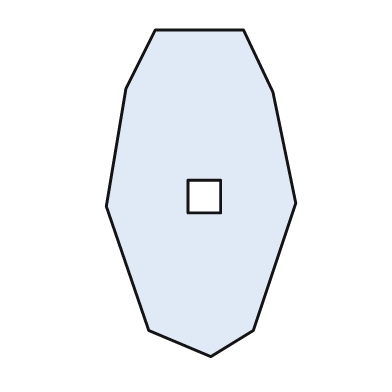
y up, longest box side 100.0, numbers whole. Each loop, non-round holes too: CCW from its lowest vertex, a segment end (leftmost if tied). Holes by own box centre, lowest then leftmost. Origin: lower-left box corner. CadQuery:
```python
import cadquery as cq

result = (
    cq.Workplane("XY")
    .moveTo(32.0, 0.0)
    .lineTo(45.0, 8.0)
    .lineTo(58.0, 47.0)
    .lineTo(51.0, 81.0)
    .lineTo(42.0, 100.0)
    .lineTo(15.0, 100.0)
    .lineTo(6.0, 82.0)
    .lineTo(0.0, 46.0)
    .lineTo(13.0, 8.0)
    .close()
    .moveTo(25.0, 44.0)
    .lineTo(35.0, 44.0)
    .lineTo(35.0, 54.0)
    .lineTo(25.0, 54.0)
    .close()
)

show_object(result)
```